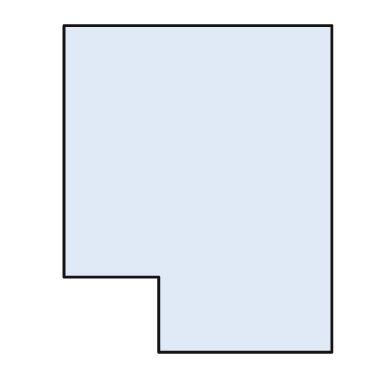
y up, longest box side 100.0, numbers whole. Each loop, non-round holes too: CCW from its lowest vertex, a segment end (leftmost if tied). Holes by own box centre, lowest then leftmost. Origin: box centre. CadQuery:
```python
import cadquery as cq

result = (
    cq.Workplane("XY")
    .moveTo(-12.0, -50.0)
    .lineTo(41.0, -50.0)
    .lineTo(41.0, 50.0)
    .lineTo(-41.0, 50.0)
    .lineTo(-41.0, -27.0)
    .lineTo(-12.0, -27.0)
    .close()
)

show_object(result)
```